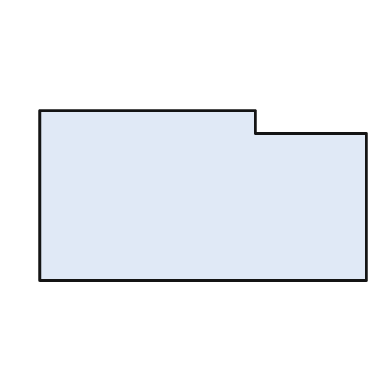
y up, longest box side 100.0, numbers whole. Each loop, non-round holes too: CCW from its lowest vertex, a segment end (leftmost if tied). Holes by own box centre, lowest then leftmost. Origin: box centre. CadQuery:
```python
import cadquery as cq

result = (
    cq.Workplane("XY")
    .moveTo(-50.0, -26.0)
    .lineTo(50.0, -26.0)
    .lineTo(50.0, 19.0)
    .lineTo(16.0, 19.0)
    .lineTo(16.0, 26.0)
    .lineTo(-50.0, 26.0)
    .close()
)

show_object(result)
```